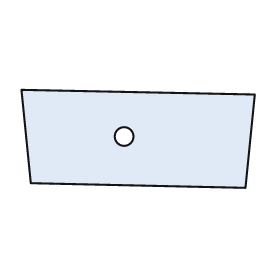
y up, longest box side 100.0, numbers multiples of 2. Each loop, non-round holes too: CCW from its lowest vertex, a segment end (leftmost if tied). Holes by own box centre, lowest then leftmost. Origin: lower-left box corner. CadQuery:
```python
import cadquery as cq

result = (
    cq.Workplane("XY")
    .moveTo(96.0, 0.0)
    .lineTo(100.0, 40.0)
    .lineTo(0.0, 42.0)
    .lineTo(4.0, 2.0)
    .close()
    .moveTo(44.0, 22.0)
    .circle(4.0)
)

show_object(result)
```